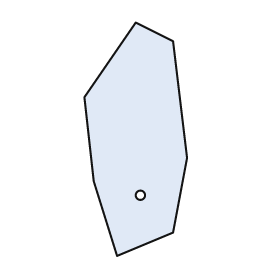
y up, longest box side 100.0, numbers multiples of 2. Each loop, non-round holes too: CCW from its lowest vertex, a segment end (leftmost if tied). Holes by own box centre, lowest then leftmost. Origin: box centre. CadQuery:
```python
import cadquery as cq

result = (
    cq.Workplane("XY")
    .moveTo(-8.0, -50.0)
    .lineTo(16.0, -40.0)
    .lineTo(22.0, -8.0)
    .lineTo(16.0, 42.0)
    .lineTo(0.0, 50.0)
    .lineTo(-22.0, 18.0)
    .lineTo(-18.0, -18.0)
    .close()
    .moveTo(2.0, -24.0)
    .circle(2.0)
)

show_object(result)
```